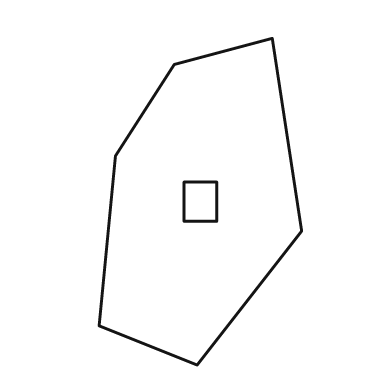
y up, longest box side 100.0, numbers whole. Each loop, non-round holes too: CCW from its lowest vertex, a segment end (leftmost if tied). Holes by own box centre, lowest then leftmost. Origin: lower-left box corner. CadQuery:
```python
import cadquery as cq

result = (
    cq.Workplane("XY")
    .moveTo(30.0, 0.0)
    .lineTo(62.0, 41.0)
    .lineTo(53.0, 100.0)
    .lineTo(23.0, 92.0)
    .lineTo(5.0, 64.0)
    .lineTo(0.0, 12.0)
    .close()
    .moveTo(26.0, 44.0)
    .lineTo(36.0, 44.0)
    .lineTo(36.0, 56.0)
    .lineTo(26.0, 56.0)
    .close()
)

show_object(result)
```